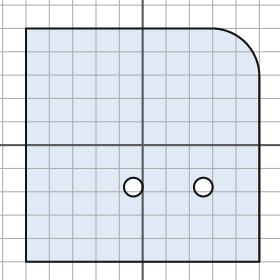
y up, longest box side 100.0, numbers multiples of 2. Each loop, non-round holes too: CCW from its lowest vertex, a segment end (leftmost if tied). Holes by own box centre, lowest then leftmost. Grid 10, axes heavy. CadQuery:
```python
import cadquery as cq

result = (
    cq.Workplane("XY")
    .moveTo(-50.0, -50.0)
    .lineTo(50.0, -50.0)
    .lineTo(50.0, 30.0)
    .threePointArc((44.0, 44.0), (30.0, 50.0))
    .lineTo(-50.0, 50.0)
    .close()
    .moveTo(-4.0, -18.0)
    .circle(4.0)
    .moveTo(26.0, -18.0)
    .circle(4.0)
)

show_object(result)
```